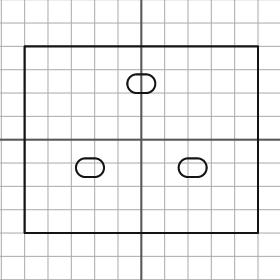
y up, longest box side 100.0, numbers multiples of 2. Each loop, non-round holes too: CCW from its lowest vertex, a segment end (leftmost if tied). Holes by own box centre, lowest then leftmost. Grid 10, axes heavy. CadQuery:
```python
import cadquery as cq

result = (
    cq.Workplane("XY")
    .moveTo(-50.0, -40.0)
    .lineTo(50.0, -40.0)
    .lineTo(50.0, 40.0)
    .lineTo(-50.0, 40.0)
    .close()
    .moveTo(-24.0, -16.0)
    .lineTo(-20.0, -16.0)
    .threePointArc((-16.0, -12.0), (-20.0, -8.0))
    .lineTo(-24.0, -8.0)
    .threePointArc((-28.0, -12.0), (-24.0, -16.0))
    .close()
    .moveTo(20.0, -16.0)
    .lineTo(24.0, -16.0)
    .threePointArc((28.0, -12.0), (24.0, -8.0))
    .lineTo(20.0, -8.0)
    .threePointArc((16.0, -12.0), (20.0, -16.0))
    .close()
    .moveTo(-2.0, 20.0)
    .lineTo(2.0, 20.0)
    .threePointArc((6.0, 24.0), (2.0, 28.0))
    .lineTo(-2.0, 28.0)
    .threePointArc((-6.0, 24.0), (-2.0, 20.0))
    .close()
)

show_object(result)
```